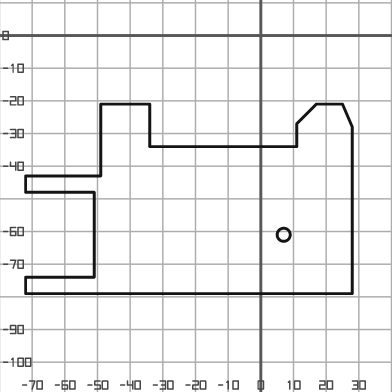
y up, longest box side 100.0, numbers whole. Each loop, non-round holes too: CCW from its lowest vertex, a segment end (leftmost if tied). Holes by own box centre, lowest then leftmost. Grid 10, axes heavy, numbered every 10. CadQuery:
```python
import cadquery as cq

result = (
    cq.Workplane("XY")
    .moveTo(-72.0, -79.0)
    .lineTo(28.0, -79.0)
    .lineTo(28.0, -28.0)
    .lineTo(25.0, -21.0)
    .lineTo(17.0, -21.0)
    .lineTo(11.0, -27.0)
    .lineTo(11.0, -34.0)
    .lineTo(-34.0, -34.0)
    .lineTo(-34.0, -21.0)
    .lineTo(-49.0, -21.0)
    .lineTo(-49.0, -43.0)
    .lineTo(-72.0, -43.0)
    .lineTo(-72.0, -48.0)
    .lineTo(-51.0, -48.0)
    .lineTo(-51.0, -74.0)
    .lineTo(-72.0, -74.0)
    .close()
    .moveTo(7.0, -61.0)
    .circle(2.0)
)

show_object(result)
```